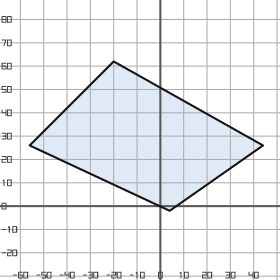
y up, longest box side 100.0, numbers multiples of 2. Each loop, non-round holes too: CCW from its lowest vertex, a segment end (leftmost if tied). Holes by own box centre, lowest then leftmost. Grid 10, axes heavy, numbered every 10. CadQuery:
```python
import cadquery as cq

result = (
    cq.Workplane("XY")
    .moveTo(4.0, -2.0)
    .lineTo(44.0, 26.0)
    .lineTo(-20.0, 62.0)
    .lineTo(-56.0, 26.0)
    .close()
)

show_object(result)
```